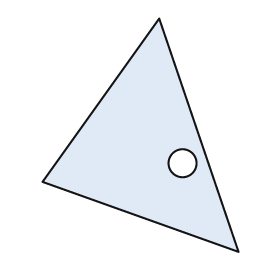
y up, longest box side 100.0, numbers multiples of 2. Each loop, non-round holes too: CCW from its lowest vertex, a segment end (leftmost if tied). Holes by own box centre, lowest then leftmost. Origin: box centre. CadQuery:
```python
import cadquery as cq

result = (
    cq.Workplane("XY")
    .moveTo(42.0, -50.0)
    .lineTo(8.0, 50.0)
    .lineTo(-42.0, -20.0)
    .close()
    .moveTo(18.0, -12.0)
    .circle(6.0)
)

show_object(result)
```